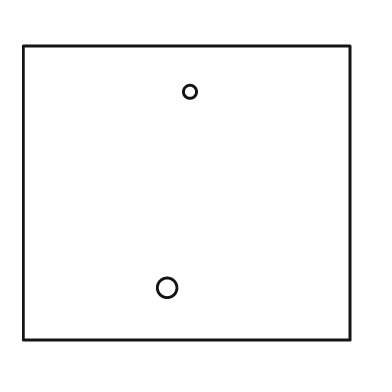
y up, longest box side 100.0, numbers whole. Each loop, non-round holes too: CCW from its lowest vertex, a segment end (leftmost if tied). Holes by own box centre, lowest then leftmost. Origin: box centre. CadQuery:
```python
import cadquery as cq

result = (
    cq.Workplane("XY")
    .moveTo(-50.0, -45.0)
    .lineTo(50.0, -45.0)
    .lineTo(50.0, 45.0)
    .lineTo(-50.0, 45.0)
    .close()
    .moveTo(-6.0, -29.0)
    .circle(3.0)
    .moveTo(1.0, 31.0)
    .circle(2.0)
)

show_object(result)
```